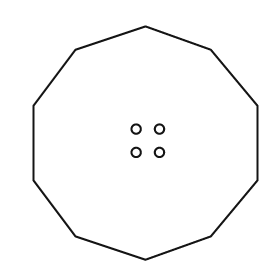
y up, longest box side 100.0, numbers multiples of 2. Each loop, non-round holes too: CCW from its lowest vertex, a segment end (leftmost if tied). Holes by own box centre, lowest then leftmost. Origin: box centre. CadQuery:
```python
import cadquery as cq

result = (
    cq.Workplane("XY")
    .moveTo(0.0, -50.0)
    .lineTo(28.0, -40.0)
    .lineTo(48.0, -16.0)
    .lineTo(48.0, 16.0)
    .lineTo(28.0, 40.0)
    .lineTo(0.0, 50.0)
    .lineTo(-30.0, 40.0)
    .lineTo(-48.0, 16.0)
    .lineTo(-48.0, -16.0)
    .lineTo(-30.0, -40.0)
    .close()
    .moveTo(-4.0, -4.0)
    .circle(2.0)
    .moveTo(6.0, -4.0)
    .circle(2.0)
    .moveTo(-4.0, 6.0)
    .circle(2.0)
    .moveTo(6.0, 6.0)
    .circle(2.0)
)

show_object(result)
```